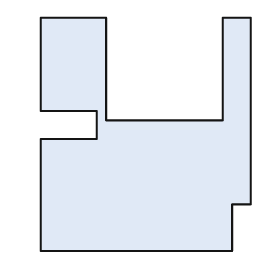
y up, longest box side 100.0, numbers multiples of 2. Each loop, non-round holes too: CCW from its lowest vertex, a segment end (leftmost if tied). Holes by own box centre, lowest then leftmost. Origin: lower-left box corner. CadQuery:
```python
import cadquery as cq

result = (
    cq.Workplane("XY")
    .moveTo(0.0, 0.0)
    .lineTo(82.0, 0.0)
    .lineTo(82.0, 20.0)
    .lineTo(90.0, 20.0)
    .lineTo(90.0, 100.0)
    .lineTo(78.0, 100.0)
    .lineTo(78.0, 56.0)
    .lineTo(28.0, 56.0)
    .lineTo(28.0, 100.0)
    .lineTo(0.0, 100.0)
    .lineTo(0.0, 60.0)
    .lineTo(24.0, 60.0)
    .lineTo(24.0, 48.0)
    .lineTo(0.0, 48.0)
    .close()
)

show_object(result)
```